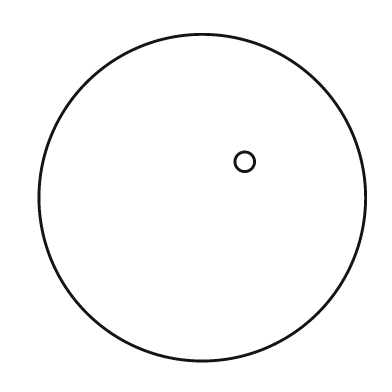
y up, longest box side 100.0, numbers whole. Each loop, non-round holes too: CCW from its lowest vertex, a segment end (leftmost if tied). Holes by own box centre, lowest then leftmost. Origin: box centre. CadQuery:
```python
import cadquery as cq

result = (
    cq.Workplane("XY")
    .moveTo(0.0, 0.0)
    .circle(50.0)
    .moveTo(13.0, 11.0)
    .circle(3.0)
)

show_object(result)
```